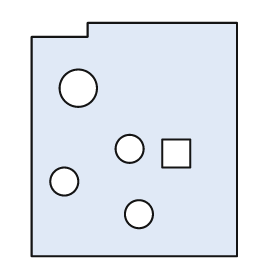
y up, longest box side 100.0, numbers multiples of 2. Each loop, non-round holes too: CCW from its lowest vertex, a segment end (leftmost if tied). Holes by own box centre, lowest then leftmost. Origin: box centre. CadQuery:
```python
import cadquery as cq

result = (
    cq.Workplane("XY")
    .moveTo(-44.0, -50.0)
    .lineTo(44.0, -50.0)
    .lineTo(44.0, 50.0)
    .lineTo(-20.0, 50.0)
    .lineTo(-20.0, 44.0)
    .lineTo(-44.0, 44.0)
    .close()
    .moveTo(2.0, -32.0)
    .circle(6.0)
    .moveTo(-30.0, -18.0)
    .circle(6.0)
    .moveTo(12.0, -12.0)
    .lineTo(24.0, -12.0)
    .lineTo(24.0, 0.0)
    .lineTo(12.0, 0.0)
    .close()
    .moveTo(-2.0, -4.0)
    .circle(6.0)
    .moveTo(-24.0, 22.0)
    .circle(8.0)
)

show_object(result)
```